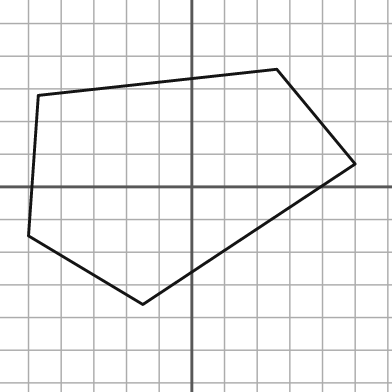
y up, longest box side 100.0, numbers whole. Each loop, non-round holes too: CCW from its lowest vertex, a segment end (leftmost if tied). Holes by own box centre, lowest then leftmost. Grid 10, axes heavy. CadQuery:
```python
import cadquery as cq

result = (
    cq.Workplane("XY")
    .moveTo(-15.0, -36.0)
    .lineTo(50.0, 7.0)
    .lineTo(26.0, 36.0)
    .lineTo(-47.0, 28.0)
    .lineTo(-50.0, -15.0)
    .close()
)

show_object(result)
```